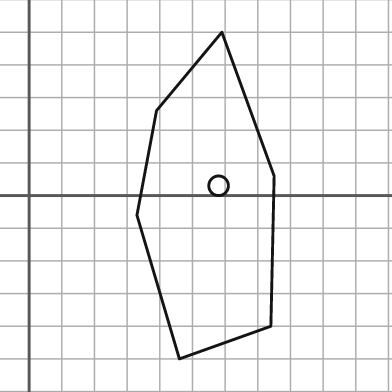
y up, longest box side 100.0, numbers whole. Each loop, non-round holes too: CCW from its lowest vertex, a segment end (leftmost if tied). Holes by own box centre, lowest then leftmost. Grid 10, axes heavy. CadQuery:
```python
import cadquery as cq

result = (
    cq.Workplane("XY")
    .moveTo(46.0, -50.0)
    .lineTo(74.0, -40.0)
    .lineTo(75.0, 6.0)
    .lineTo(59.0, 50.0)
    .lineTo(39.0, 26.0)
    .lineTo(33.0, -6.0)
    .close()
    .moveTo(58.0, 3.0)
    .circle(3.0)
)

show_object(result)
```